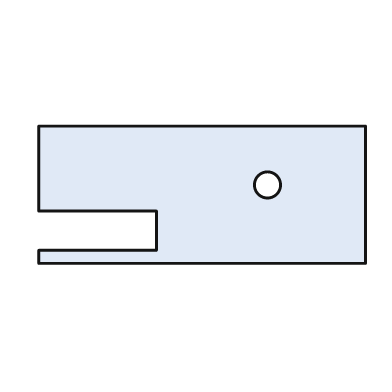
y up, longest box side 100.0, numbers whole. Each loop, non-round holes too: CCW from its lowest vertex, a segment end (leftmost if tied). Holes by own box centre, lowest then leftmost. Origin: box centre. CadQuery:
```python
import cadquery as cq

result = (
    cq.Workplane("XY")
    .moveTo(-50.0, -21.0)
    .lineTo(50.0, -21.0)
    .lineTo(50.0, 21.0)
    .lineTo(-50.0, 21.0)
    .lineTo(-50.0, -5.0)
    .lineTo(-14.0, -5.0)
    .lineTo(-14.0, -17.0)
    .lineTo(-50.0, -17.0)
    .close()
    .moveTo(20.0, 3.0)
    .circle(4.0)
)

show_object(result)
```